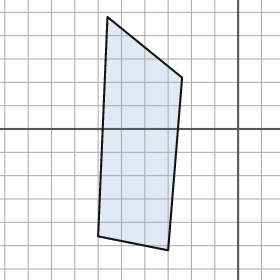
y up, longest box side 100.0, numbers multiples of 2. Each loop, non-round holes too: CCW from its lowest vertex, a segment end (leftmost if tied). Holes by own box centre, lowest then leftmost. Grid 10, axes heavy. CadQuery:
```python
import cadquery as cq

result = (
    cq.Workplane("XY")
    .moveTo(-30.0, -52.0)
    .lineTo(-24.0, 22.0)
    .lineTo(-56.0, 48.0)
    .lineTo(-60.0, -46.0)
    .close()
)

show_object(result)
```